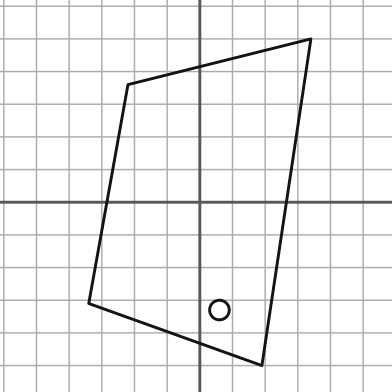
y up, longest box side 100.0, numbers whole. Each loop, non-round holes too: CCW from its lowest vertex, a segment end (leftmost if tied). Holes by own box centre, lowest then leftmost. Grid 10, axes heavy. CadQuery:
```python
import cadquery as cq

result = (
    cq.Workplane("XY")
    .moveTo(19.0, -50.0)
    .lineTo(34.0, 50.0)
    .lineTo(-22.0, 36.0)
    .lineTo(-34.0, -31.0)
    .close()
    .moveTo(6.0, -33.0)
    .circle(3.0)
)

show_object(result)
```